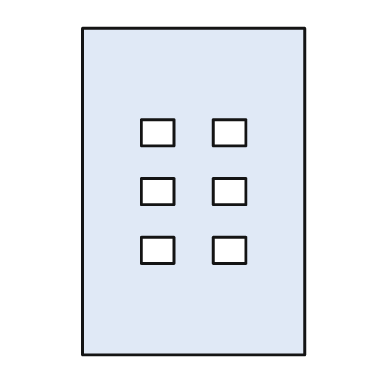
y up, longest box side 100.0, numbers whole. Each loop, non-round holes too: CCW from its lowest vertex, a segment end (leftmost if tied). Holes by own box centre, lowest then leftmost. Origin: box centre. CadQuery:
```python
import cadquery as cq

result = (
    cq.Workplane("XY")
    .moveTo(-34.0, -50.0)
    .lineTo(34.0, -50.0)
    .lineTo(34.0, 50.0)
    .lineTo(-34.0, 50.0)
    .close()
    .moveTo(-16.0, -22.0)
    .lineTo(-6.0, -22.0)
    .lineTo(-6.0, -14.0)
    .lineTo(-16.0, -14.0)
    .close()
    .moveTo(6.0, -22.0)
    .lineTo(16.0, -22.0)
    .lineTo(16.0, -14.0)
    .lineTo(6.0, -14.0)
    .close()
    .moveTo(-16.0, -4.0)
    .lineTo(-6.0, -4.0)
    .lineTo(-6.0, 4.0)
    .lineTo(-16.0, 4.0)
    .close()
    .moveTo(6.0, -4.0)
    .lineTo(16.0, -4.0)
    .lineTo(16.0, 4.0)
    .lineTo(6.0, 4.0)
    .close()
    .moveTo(-16.0, 14.0)
    .lineTo(-6.0, 14.0)
    .lineTo(-6.0, 22.0)
    .lineTo(-16.0, 22.0)
    .close()
    .moveTo(6.0, 14.0)
    .lineTo(16.0, 14.0)
    .lineTo(16.0, 22.0)
    .lineTo(6.0, 22.0)
    .close()
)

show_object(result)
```